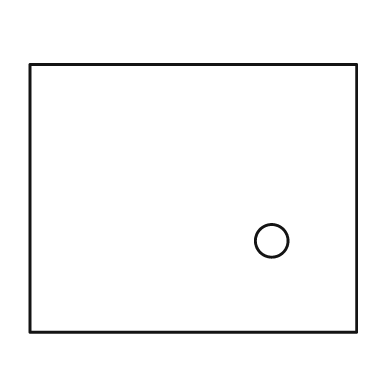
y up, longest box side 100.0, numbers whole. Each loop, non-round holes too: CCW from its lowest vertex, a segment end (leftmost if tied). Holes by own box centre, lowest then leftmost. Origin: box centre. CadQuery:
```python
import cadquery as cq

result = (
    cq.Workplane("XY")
    .moveTo(-50.0, -41.0)
    .lineTo(50.0, -41.0)
    .lineTo(50.0, 41.0)
    .lineTo(-50.0, 41.0)
    .close()
    .moveTo(24.0, -13.0)
    .circle(5.0)
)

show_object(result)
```